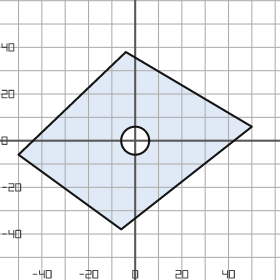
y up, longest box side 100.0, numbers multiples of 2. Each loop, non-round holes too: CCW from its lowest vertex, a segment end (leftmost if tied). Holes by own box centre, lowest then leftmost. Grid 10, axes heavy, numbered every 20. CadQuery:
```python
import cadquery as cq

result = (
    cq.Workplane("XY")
    .moveTo(-6.0, -38.0)
    .lineTo(50.0, 6.0)
    .lineTo(-4.0, 38.0)
    .lineTo(-50.0, -6.0)
    .close()
    .moveTo(0.0, 0.0)
    .circle(6.0)
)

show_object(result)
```